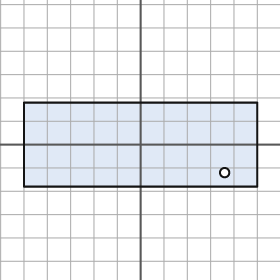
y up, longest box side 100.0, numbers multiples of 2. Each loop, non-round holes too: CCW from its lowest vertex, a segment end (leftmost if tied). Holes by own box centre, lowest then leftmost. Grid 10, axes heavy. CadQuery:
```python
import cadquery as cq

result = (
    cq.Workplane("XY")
    .moveTo(-50.0, -18.0)
    .lineTo(50.0, -18.0)
    .lineTo(50.0, 18.0)
    .lineTo(-50.0, 18.0)
    .close()
    .moveTo(36.0, -12.0)
    .circle(2.0)
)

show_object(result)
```